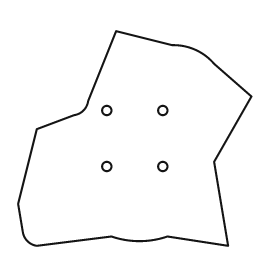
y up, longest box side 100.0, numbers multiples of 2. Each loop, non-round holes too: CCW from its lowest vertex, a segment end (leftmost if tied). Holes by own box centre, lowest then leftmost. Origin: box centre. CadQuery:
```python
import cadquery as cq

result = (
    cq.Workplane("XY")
    .moveTo(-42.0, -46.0)
    .lineTo(-10.0, -42.0)
    .threePointArc((2.0, -44.0), (14.0, -42.0))
    .lineTo(40.0, -46.0)
    .lineTo(34.0, -10.0)
    .lineTo(50.0, 18.0)
    .lineTo(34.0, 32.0)
    .threePointArc((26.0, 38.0), (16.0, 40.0))
    .lineTo(-8.0, 46.0)
    .lineTo(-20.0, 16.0)
    .threePointArc((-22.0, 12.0), (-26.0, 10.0))
    .lineTo(-42.0, 4.0)
    .lineTo(-50.0, -28.0)
    .lineTo(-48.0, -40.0)
    .threePointArc((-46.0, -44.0), (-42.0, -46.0))
    .close()
    .moveTo(-12.0, -12.0)
    .circle(2.0)
    .moveTo(12.0, -12.0)
    .circle(2.0)
    .moveTo(-12.0, 12.0)
    .circle(2.0)
    .moveTo(12.0, 12.0)
    .circle(2.0)
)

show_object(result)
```